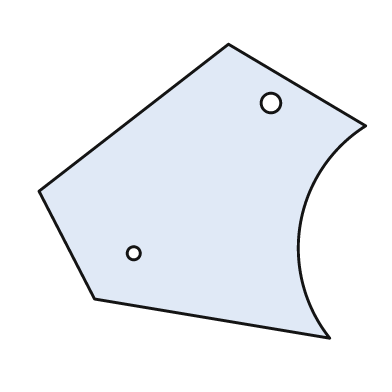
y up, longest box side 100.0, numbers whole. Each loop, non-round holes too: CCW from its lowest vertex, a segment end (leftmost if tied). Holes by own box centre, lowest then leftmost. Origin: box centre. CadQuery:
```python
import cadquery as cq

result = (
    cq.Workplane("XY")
    .moveTo(39.0, -45.0)
    .threePointArc((30.0, -10.0), (50.0, 20.0))
    .lineTo(8.0, 45.0)
    .lineTo(-50.0, 0.0)
    .lineTo(-33.0, -33.0)
    .close()
    .moveTo(-21.0, -19.0)
    .circle(2.0)
    .moveTo(21.0, 27.0)
    .circle(3.0)
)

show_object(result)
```